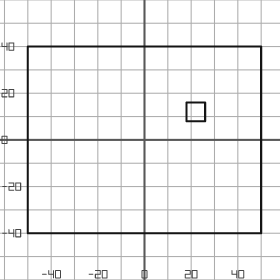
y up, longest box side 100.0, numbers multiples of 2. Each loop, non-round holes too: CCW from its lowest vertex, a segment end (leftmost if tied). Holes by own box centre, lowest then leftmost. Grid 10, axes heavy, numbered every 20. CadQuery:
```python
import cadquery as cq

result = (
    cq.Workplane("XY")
    .moveTo(-50.0, -40.0)
    .lineTo(50.0, -40.0)
    .lineTo(50.0, 40.0)
    .lineTo(-50.0, 40.0)
    .close()
    .moveTo(18.0, 8.0)
    .lineTo(26.0, 8.0)
    .lineTo(26.0, 16.0)
    .lineTo(18.0, 16.0)
    .close()
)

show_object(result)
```